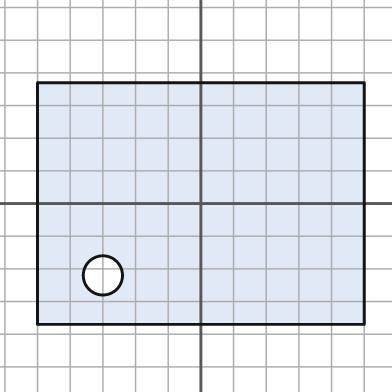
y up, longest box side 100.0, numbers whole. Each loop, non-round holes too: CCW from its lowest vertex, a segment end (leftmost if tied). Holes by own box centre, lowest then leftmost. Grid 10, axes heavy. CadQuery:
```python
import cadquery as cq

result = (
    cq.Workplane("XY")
    .moveTo(-50.0, -37.0)
    .lineTo(50.0, -37.0)
    .lineTo(50.0, 37.0)
    .lineTo(-50.0, 37.0)
    .close()
    .moveTo(-30.0, -22.0)
    .circle(6.0)
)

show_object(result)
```